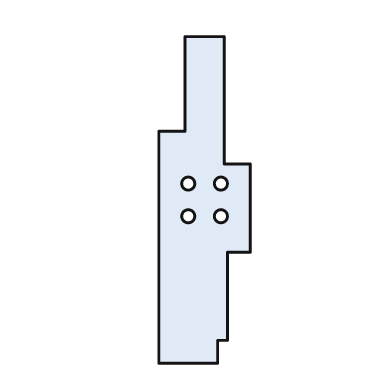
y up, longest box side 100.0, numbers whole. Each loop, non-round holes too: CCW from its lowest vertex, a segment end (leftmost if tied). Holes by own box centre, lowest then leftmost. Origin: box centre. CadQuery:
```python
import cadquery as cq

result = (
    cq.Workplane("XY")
    .moveTo(-14.0, -50.0)
    .lineTo(4.0, -50.0)
    .lineTo(4.0, -43.0)
    .lineTo(7.0, -43.0)
    .lineTo(7.0, -16.0)
    .lineTo(14.0, -16.0)
    .lineTo(14.0, 11.0)
    .lineTo(6.0, 11.0)
    .lineTo(6.0, 50.0)
    .lineTo(-6.0, 50.0)
    .lineTo(-6.0, 21.0)
    .lineTo(-14.0, 21.0)
    .close()
    .moveTo(-5.0, -5.0)
    .circle(2.0)
    .moveTo(5.0, -5.0)
    .circle(2.0)
    .moveTo(-5.0, 5.0)
    .circle(2.0)
    .moveTo(5.0, 5.0)
    .circle(2.0)
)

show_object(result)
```